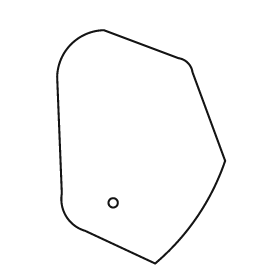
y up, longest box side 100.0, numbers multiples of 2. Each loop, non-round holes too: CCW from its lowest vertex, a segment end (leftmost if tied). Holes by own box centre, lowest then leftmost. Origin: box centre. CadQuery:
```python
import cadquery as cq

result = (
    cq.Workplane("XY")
    .moveTo(6.0, -50.0)
    .threePointArc((24.0, -30.0), (36.0, -6.0))
    .lineTo(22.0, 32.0)
    .threePointArc((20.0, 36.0), (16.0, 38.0))
    .lineTo(-16.0, 50.0)
    .threePointArc((-30.0, 44.0), (-36.0, 30.0))
    .lineTo(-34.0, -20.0)
    .threePointArc((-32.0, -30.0), (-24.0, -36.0))
    .close()
    .moveTo(-12.0, -24.0)
    .circle(2.0)
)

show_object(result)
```